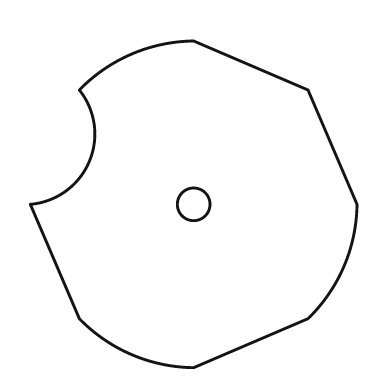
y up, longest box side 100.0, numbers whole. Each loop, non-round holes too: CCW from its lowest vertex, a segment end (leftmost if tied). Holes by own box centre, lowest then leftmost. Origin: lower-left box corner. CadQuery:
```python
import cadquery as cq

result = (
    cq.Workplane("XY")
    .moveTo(50.0, 0.0)
    .lineTo(85.0, 15.0)
    .threePointArc((96.0, 31.0), (100.0, 50.0))
    .lineTo(85.0, 85.0)
    .lineTo(50.0, 100.0)
    .threePointArc((31.0, 96.0), (15.0, 85.0))
    .threePointArc((18.0, 63.0), (0.0, 50.0))
    .lineTo(15.0, 15.0)
    .threePointArc((31.0, 4.0), (50.0, 0.0))
    .close()
    .moveTo(50.0, 50.0)
    .circle(5.0)
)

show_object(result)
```